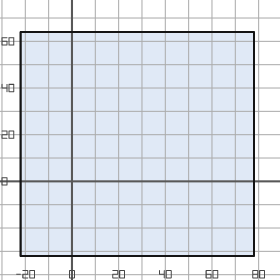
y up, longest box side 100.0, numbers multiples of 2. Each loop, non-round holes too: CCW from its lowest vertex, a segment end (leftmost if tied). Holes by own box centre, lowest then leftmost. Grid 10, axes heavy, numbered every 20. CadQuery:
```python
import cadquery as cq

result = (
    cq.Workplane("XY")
    .moveTo(-22.0, -32.0)
    .lineTo(78.0, -32.0)
    .lineTo(78.0, 64.0)
    .lineTo(-22.0, 64.0)
    .close()
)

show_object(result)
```